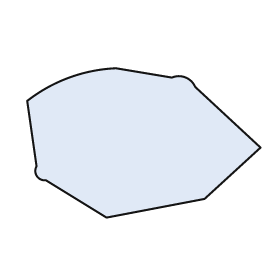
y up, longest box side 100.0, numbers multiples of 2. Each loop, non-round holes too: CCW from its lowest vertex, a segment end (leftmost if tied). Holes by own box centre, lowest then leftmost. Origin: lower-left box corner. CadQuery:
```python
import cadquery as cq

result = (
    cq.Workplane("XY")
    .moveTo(34.0, 0.0)
    .lineTo(76.0, 8.0)
    .lineTo(100.0, 30.0)
    .lineTo(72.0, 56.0)
    .threePointArc((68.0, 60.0), (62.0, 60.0))
    .lineTo(38.0, 64.0)
    .threePointArc((18.0, 60.0), (0.0, 50.0))
    .lineTo(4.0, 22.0)
    .threePointArc((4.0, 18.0), (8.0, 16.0))
    .close()
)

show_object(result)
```